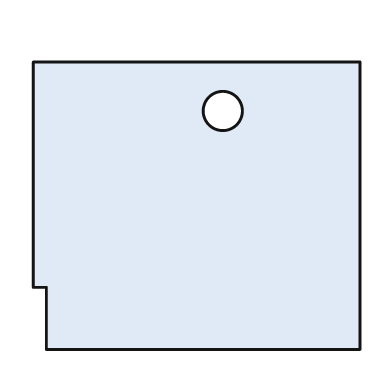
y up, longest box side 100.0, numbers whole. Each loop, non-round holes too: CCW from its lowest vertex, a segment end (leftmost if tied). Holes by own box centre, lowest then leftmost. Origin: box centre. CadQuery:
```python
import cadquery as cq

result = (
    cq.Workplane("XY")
    .moveTo(-46.0, -44.0)
    .lineTo(50.0, -44.0)
    .lineTo(50.0, 44.0)
    .lineTo(-50.0, 44.0)
    .lineTo(-50.0, -25.0)
    .lineTo(-46.0, -25.0)
    .close()
    .moveTo(8.0, 29.0)
    .circle(6.0)
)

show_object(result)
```